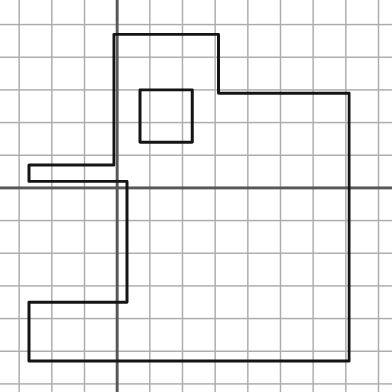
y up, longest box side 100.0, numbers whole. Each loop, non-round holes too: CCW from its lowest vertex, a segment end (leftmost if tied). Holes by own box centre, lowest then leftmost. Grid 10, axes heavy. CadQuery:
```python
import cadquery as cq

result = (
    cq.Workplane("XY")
    .moveTo(-27.0, -53.0)
    .lineTo(71.0, -53.0)
    .lineTo(71.0, 29.0)
    .lineTo(31.0, 29.0)
    .lineTo(31.0, 47.0)
    .lineTo(-1.0, 47.0)
    .lineTo(-1.0, 7.0)
    .lineTo(-27.0, 7.0)
    .lineTo(-27.0, 2.0)
    .lineTo(3.0, 2.0)
    .lineTo(3.0, -35.0)
    .lineTo(-27.0, -35.0)
    .close()
    .moveTo(7.0, 14.0)
    .lineTo(23.0, 14.0)
    .lineTo(23.0, 30.0)
    .lineTo(7.0, 30.0)
    .close()
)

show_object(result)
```